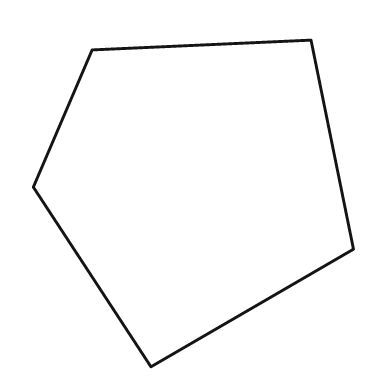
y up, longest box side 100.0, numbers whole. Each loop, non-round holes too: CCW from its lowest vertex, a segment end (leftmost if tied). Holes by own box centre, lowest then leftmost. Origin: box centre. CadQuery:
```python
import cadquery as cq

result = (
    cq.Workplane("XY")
    .moveTo(-13.0, -50.0)
    .lineTo(49.0, -14.0)
    .lineTo(36.0, 50.0)
    .lineTo(-31.0, 47.0)
    .lineTo(-49.0, 5.0)
    .close()
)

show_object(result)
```